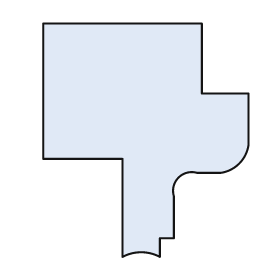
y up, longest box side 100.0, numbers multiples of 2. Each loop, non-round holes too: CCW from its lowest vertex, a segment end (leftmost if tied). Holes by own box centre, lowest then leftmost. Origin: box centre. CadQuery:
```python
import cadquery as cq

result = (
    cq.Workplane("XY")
    .moveTo(-10.0, -50.0)
    .threePointArc((-2.0, -48.0), (6.0, -50.0))
    .lineTo(6.0, -42.0)
    .lineTo(12.0, -42.0)
    .lineTo(12.0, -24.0)
    .threePointArc((14.0, -16.0), (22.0, -14.0))
    .lineTo(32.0, -14.0)
    .threePointArc((40.0, -10.0), (44.0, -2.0))
    .lineTo(44.0, 20.0)
    .lineTo(24.0, 20.0)
    .lineTo(24.0, 50.0)
    .lineTo(-44.0, 50.0)
    .lineTo(-44.0, -8.0)
    .lineTo(-10.0, -8.0)
    .close()
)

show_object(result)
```